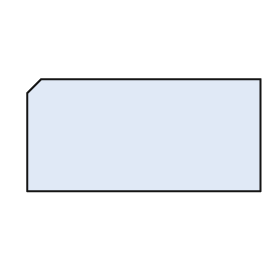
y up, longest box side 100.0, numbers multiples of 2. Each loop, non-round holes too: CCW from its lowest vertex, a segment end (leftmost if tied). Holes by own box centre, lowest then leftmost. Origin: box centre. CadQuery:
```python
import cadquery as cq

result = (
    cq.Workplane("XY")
    .moveTo(-50.0, -24.0)
    .lineTo(50.0, -24.0)
    .lineTo(50.0, 24.0)
    .lineTo(-44.0, 24.0)
    .lineTo(-50.0, 18.0)
    .close()
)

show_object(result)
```